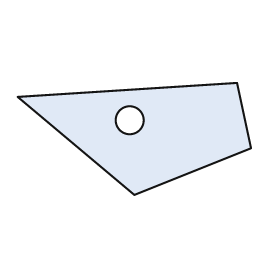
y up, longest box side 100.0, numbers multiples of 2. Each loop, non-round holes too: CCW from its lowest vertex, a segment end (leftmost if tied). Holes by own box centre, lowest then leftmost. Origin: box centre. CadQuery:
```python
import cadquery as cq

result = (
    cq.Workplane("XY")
    .moveTo(0.0, -24.0)
    .lineTo(50.0, -4.0)
    .lineTo(44.0, 24.0)
    .lineTo(-50.0, 18.0)
    .close()
    .moveTo(-2.0, 8.0)
    .circle(6.0)
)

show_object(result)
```